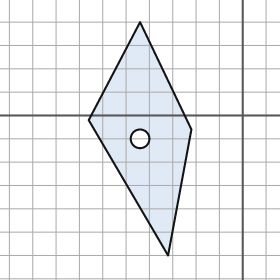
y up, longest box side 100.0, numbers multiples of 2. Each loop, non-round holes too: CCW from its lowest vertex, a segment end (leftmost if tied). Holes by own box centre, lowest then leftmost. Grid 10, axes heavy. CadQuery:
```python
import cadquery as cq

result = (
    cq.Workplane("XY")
    .moveTo(-32.0, -60.0)
    .lineTo(-22.0, -6.0)
    .lineTo(-44.0, 40.0)
    .lineTo(-66.0, -2.0)
    .close()
    .moveTo(-44.0, -10.0)
    .circle(4.0)
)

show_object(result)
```